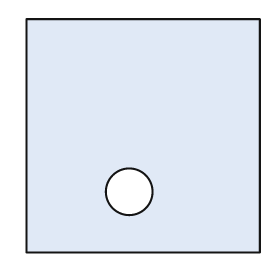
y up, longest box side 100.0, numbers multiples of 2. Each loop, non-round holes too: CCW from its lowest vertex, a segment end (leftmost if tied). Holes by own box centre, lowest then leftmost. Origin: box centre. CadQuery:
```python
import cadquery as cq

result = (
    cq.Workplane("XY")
    .moveTo(-50.0, -50.0)
    .lineTo(50.0, -50.0)
    .lineTo(50.0, 50.0)
    .lineTo(-50.0, 50.0)
    .close()
    .moveTo(-6.0, -24.0)
    .circle(10.0)
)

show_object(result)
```